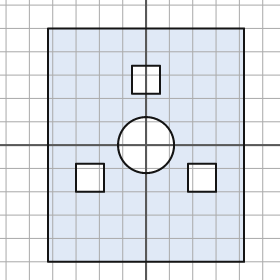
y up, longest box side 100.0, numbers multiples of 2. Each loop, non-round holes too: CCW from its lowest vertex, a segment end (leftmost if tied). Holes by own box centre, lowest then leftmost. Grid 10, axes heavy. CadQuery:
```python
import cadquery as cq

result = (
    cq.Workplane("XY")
    .moveTo(-42.0, -50.0)
    .lineTo(42.0, -50.0)
    .lineTo(42.0, 50.0)
    .lineTo(-42.0, 50.0)
    .close()
    .moveTo(-30.0, -20.0)
    .lineTo(-18.0, -20.0)
    .lineTo(-18.0, -8.0)
    .lineTo(-30.0, -8.0)
    .close()
    .moveTo(18.0, -20.0)
    .lineTo(30.0, -20.0)
    .lineTo(30.0, -8.0)
    .lineTo(18.0, -8.0)
    .close()
    .moveTo(0.0, 0.0)
    .circle(12.0)
    .moveTo(-6.0, 22.0)
    .lineTo(6.0, 22.0)
    .lineTo(6.0, 34.0)
    .lineTo(-6.0, 34.0)
    .close()
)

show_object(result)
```